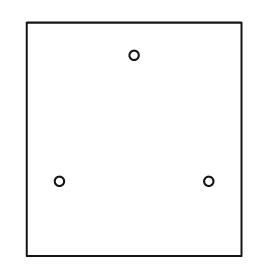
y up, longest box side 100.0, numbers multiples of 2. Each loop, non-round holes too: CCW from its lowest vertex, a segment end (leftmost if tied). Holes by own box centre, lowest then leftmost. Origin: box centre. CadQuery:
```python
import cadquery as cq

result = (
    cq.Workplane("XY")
    .moveTo(-46.0, -50.0)
    .lineTo(46.0, -50.0)
    .lineTo(46.0, 50.0)
    .lineTo(-46.0, 50.0)
    .close()
    .moveTo(-32.0, -18.0)
    .circle(2.0)
    .moveTo(32.0, -18.0)
    .circle(2.0)
    .moveTo(0.0, 36.0)
    .circle(2.0)
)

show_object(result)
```